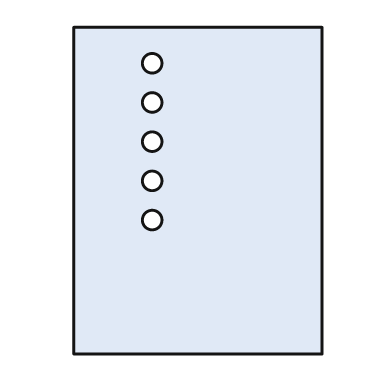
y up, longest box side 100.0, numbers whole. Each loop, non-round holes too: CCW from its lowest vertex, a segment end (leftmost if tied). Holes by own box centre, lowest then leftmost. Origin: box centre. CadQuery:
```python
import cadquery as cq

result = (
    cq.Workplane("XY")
    .moveTo(-38.0, -50.0)
    .lineTo(38.0, -50.0)
    .lineTo(38.0, 50.0)
    .lineTo(-38.0, 50.0)
    .close()
    .moveTo(-14.0, -9.0)
    .circle(3.0)
    .moveTo(-14.0, 3.0)
    .circle(3.0)
    .moveTo(-14.0, 15.0)
    .circle(3.0)
    .moveTo(-14.0, 27.0)
    .circle(3.0)
    .moveTo(-14.0, 39.0)
    .circle(3.0)
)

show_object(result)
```